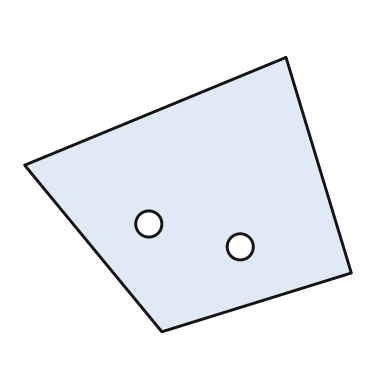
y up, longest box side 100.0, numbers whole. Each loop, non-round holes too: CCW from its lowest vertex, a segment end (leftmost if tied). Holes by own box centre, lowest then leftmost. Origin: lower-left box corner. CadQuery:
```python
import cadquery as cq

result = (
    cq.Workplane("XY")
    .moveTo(42.0, 0.0)
    .lineTo(100.0, 18.0)
    .lineTo(80.0, 84.0)
    .lineTo(0.0, 51.0)
    .close()
    .moveTo(66.0, 26.0)
    .circle(4.0)
    .moveTo(38.0, 33.0)
    .circle(4.0)
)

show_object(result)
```